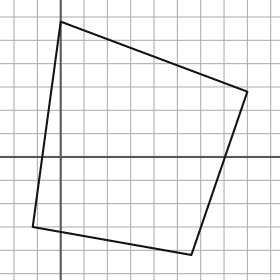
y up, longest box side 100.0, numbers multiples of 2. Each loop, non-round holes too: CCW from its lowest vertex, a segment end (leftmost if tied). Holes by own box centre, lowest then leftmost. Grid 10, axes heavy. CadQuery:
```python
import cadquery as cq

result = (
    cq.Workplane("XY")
    .moveTo(56.0, -42.0)
    .lineTo(80.0, 28.0)
    .lineTo(0.0, 58.0)
    .lineTo(-12.0, -30.0)
    .close()
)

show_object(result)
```